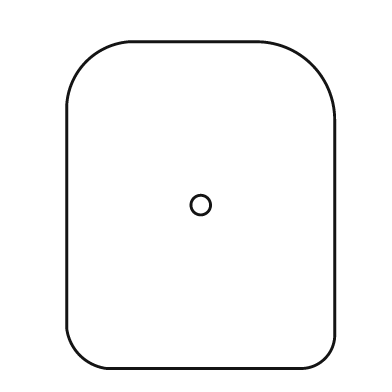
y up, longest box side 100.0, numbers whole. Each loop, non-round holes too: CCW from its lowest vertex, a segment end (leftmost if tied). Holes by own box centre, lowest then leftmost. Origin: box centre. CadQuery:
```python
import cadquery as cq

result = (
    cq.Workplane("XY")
    .moveTo(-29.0, -50.0)
    .lineTo(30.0, -50.0)
    .threePointArc((38.0, -47.0), (41.0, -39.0))
    .lineTo(41.0, 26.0)
    .threePointArc((34.0, 43.0), (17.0, 50.0))
    .lineTo(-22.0, 50.0)
    .threePointArc((-35.0, 44.0), (-41.0, 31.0))
    .lineTo(-41.0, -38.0)
    .threePointArc((-37.0, -46.0), (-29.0, -50.0))
    .close()
    .moveTo(0.0, 0.0)
    .circle(3.0)
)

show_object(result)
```